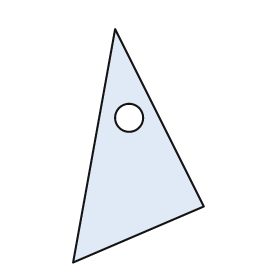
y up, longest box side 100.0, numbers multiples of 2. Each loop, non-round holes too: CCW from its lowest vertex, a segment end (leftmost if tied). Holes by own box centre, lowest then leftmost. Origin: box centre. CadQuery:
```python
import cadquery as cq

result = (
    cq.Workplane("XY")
    .moveTo(-28.0, -50.0)
    .lineTo(28.0, -26.0)
    .lineTo(-10.0, 50.0)
    .close()
    .moveTo(-4.0, 12.0)
    .circle(6.0)
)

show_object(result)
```